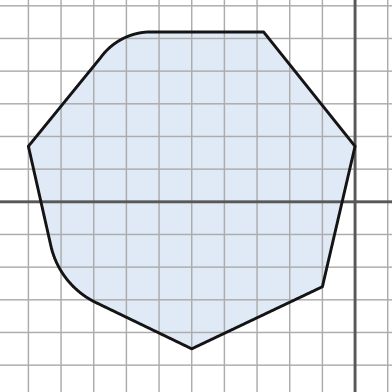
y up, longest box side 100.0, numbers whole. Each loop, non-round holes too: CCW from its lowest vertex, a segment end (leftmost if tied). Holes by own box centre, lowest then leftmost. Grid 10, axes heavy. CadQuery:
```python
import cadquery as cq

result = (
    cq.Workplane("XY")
    .moveTo(-50.0, -45.0)
    .lineTo(-10.0, -26.0)
    .lineTo(0.0, 17.0)
    .lineTo(-28.0, 52.0)
    .lineTo(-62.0, 52.0)
    .threePointArc((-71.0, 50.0), (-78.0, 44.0))
    .lineTo(-100.0, 17.0)
    .lineTo(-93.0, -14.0)
    .threePointArc((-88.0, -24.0), (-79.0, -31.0))
    .close()
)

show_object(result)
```